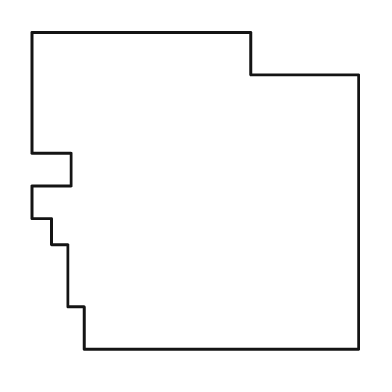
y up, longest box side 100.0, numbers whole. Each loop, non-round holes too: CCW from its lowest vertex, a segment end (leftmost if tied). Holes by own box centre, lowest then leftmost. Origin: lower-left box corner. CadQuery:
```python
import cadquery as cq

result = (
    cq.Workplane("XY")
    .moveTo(16.0, 0.0)
    .lineTo(100.0, 0.0)
    .lineTo(100.0, 84.0)
    .lineTo(67.0, 84.0)
    .lineTo(67.0, 97.0)
    .lineTo(0.0, 97.0)
    .lineTo(0.0, 60.0)
    .lineTo(12.0, 60.0)
    .lineTo(12.0, 50.0)
    .lineTo(0.0, 50.0)
    .lineTo(0.0, 40.0)
    .lineTo(6.0, 40.0)
    .lineTo(6.0, 32.0)
    .lineTo(11.0, 32.0)
    .lineTo(11.0, 13.0)
    .lineTo(16.0, 13.0)
    .close()
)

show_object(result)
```